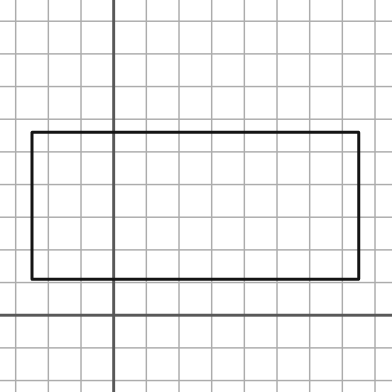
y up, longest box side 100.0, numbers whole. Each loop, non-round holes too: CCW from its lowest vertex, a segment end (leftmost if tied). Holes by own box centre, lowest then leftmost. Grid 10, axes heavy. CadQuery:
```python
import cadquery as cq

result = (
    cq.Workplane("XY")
    .moveTo(-25.0, 11.0)
    .lineTo(75.0, 11.0)
    .lineTo(75.0, 56.0)
    .lineTo(-25.0, 56.0)
    .close()
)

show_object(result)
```